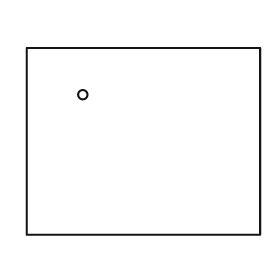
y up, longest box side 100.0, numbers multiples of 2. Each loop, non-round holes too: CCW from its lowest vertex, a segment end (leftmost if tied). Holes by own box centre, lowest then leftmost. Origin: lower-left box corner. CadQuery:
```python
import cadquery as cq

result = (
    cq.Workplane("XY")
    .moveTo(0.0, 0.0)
    .lineTo(100.0, 0.0)
    .lineTo(100.0, 80.0)
    .lineTo(0.0, 80.0)
    .close()
    .moveTo(24.0, 60.0)
    .circle(2.0)
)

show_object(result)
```